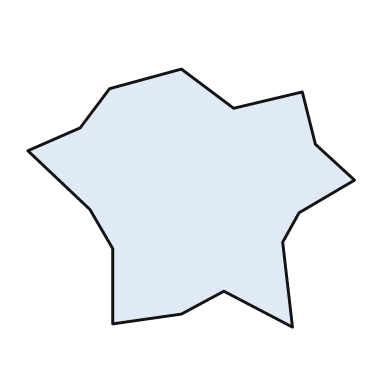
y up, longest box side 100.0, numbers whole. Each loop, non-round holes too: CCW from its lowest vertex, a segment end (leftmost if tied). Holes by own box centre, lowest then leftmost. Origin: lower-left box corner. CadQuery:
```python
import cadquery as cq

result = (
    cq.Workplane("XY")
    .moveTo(81.0, 0.0)
    .lineTo(78.0, 26.0)
    .lineTo(83.0, 35.0)
    .lineTo(100.0, 45.0)
    .lineTo(88.0, 56.0)
    .lineTo(84.0, 72.0)
    .lineTo(63.0, 67.0)
    .lineTo(47.0, 79.0)
    .lineTo(25.0, 73.0)
    .lineTo(16.0, 61.0)
    .lineTo(0.0, 54.0)
    .lineTo(19.0, 36.0)
    .lineTo(26.0, 24.0)
    .lineTo(26.0, 1.0)
    .lineTo(47.0, 4.0)
    .lineTo(60.0, 11.0)
    .close()
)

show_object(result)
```